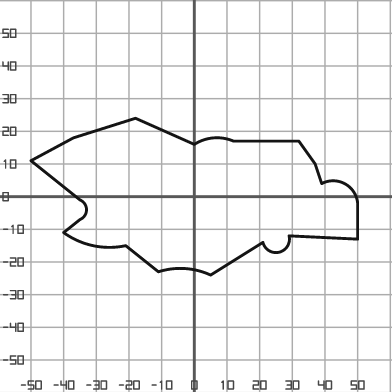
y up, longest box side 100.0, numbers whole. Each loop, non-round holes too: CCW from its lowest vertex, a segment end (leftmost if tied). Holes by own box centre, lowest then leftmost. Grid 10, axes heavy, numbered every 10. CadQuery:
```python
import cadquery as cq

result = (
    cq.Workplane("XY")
    .moveTo(5.0, -24.0)
    .lineTo(21.0, -14.0)
    .threePointArc((26.0, -17.0), (29.0, -12.0))
    .lineTo(50.0, -13.0)
    .lineTo(50.0, -2.0)
    .threePointArc((46.0, 4.0), (39.0, 4.0))
    .lineTo(37.0, 10.0)
    .lineTo(32.0, 17.0)
    .lineTo(12.0, 17.0)
    .threePointArc((6.0, 18.0), (0.0, 16.0))
    .lineTo(-18.0, 24.0)
    .lineTo(-37.0, 18.0)
    .lineTo(-50.0, 11.0)
    .lineTo(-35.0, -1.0)
    .threePointArc((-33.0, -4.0), (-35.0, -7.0))
    .lineTo(-40.0, -11.0)
    .threePointArc((-31.0, -15.0), (-21.0, -15.0))
    .lineTo(-11.0, -23.0)
    .threePointArc((-3.0, -22.0), (5.0, -24.0))
    .close()
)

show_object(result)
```